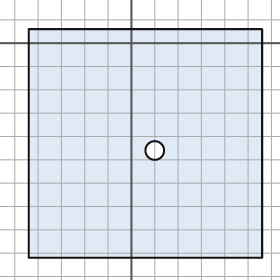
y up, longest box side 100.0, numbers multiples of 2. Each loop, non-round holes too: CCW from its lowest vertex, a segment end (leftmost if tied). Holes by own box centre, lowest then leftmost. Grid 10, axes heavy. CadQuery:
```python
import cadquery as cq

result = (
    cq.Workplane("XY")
    .moveTo(-44.0, -92.0)
    .lineTo(56.0, -92.0)
    .lineTo(56.0, 6.0)
    .lineTo(-44.0, 6.0)
    .close()
    .moveTo(10.0, -46.0)
    .circle(4.0)
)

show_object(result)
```